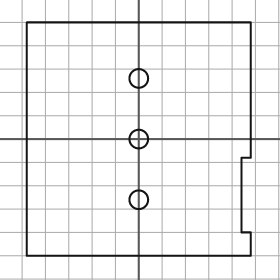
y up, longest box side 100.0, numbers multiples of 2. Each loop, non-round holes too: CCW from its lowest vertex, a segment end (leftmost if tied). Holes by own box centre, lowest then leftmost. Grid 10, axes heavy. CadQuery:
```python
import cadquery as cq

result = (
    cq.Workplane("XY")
    .moveTo(-48.0, -50.0)
    .lineTo(48.0, -50.0)
    .lineTo(48.0, -40.0)
    .lineTo(44.0, -40.0)
    .lineTo(44.0, -8.0)
    .lineTo(48.0, -8.0)
    .lineTo(48.0, 50.0)
    .lineTo(-48.0, 50.0)
    .close()
    .moveTo(0.0, -26.0)
    .circle(4.0)
    .moveTo(0.0, 0.0)
    .circle(4.0)
    .moveTo(0.0, 26.0)
    .circle(4.0)
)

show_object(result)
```